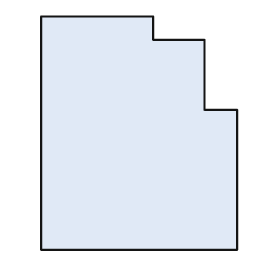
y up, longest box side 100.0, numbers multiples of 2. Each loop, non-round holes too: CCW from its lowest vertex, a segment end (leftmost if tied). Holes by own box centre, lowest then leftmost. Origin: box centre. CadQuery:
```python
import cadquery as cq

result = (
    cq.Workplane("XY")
    .moveTo(-42.0, -50.0)
    .lineTo(42.0, -50.0)
    .lineTo(42.0, 10.0)
    .lineTo(28.0, 10.0)
    .lineTo(28.0, 40.0)
    .lineTo(6.0, 40.0)
    .lineTo(6.0, 50.0)
    .lineTo(-42.0, 50.0)
    .close()
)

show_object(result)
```